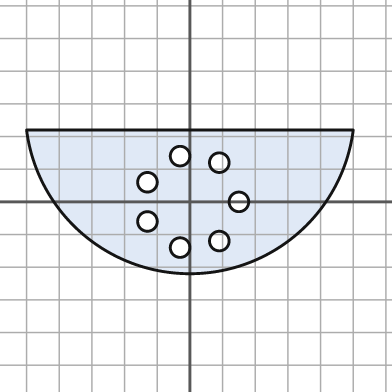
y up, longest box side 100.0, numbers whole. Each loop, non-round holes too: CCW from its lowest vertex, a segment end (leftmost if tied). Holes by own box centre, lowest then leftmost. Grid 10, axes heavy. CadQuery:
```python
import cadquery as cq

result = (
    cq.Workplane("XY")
    .moveTo(-50.0, 22.0)
    .threePointArc((0.0, -22.0), (50.0, 22.0))
    .close()
    .moveTo(-3.0, -14.0)
    .circle(3.0)
    .moveTo(9.0, -12.0)
    .circle(3.0)
    .moveTo(-13.0, -6.0)
    .circle(3.0)
    .moveTo(15.0, 0.0)
    .circle(3.0)
    .moveTo(-13.0, 6.0)
    .circle(3.0)
    .moveTo(9.0, 12.0)
    .circle(3.0)
    .moveTo(-3.0, 14.0)
    .circle(3.0)
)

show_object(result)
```